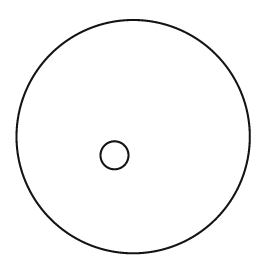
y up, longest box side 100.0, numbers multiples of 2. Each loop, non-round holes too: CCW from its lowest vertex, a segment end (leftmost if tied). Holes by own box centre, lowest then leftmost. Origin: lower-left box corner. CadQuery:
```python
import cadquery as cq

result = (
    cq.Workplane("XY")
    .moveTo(50.0, 50.0)
    .circle(50.0)
    .moveTo(42.0, 42.0)
    .circle(6.0)
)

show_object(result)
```